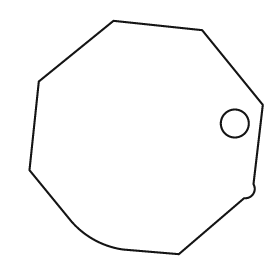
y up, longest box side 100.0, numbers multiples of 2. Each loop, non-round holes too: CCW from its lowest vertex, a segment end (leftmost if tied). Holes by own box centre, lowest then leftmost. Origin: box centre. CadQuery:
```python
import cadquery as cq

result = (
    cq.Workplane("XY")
    .moveTo(14.0, -50.0)
    .lineTo(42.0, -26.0)
    .threePointArc((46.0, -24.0), (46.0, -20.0))
    .lineTo(50.0, 14.0)
    .lineTo(24.0, 46.0)
    .lineTo(-14.0, 50.0)
    .lineTo(-46.0, 24.0)
    .lineTo(-50.0, -14.0)
    .lineTo(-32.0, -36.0)
    .threePointArc((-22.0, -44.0), (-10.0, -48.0))
    .close()
    .moveTo(38.0, 6.0)
    .circle(6.0)
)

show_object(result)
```